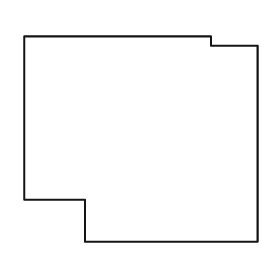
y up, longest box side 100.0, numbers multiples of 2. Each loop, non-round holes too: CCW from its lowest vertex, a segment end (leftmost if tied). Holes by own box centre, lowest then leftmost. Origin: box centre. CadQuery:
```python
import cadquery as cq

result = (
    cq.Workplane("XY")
    .moveTo(-24.0, -44.0)
    .lineTo(50.0, -44.0)
    .lineTo(50.0, 40.0)
    .lineTo(30.0, 40.0)
    .lineTo(30.0, 44.0)
    .lineTo(-50.0, 44.0)
    .lineTo(-50.0, -26.0)
    .lineTo(-24.0, -26.0)
    .close()
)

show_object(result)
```